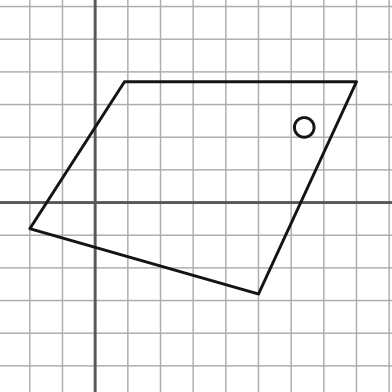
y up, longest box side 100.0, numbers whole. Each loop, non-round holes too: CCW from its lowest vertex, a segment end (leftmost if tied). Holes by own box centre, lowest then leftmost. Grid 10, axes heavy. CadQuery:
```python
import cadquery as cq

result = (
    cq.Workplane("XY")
    .moveTo(50.0, -28.0)
    .lineTo(80.0, 37.0)
    .lineTo(9.0, 37.0)
    .lineTo(-20.0, -8.0)
    .close()
    .moveTo(64.0, 23.0)
    .circle(3.0)
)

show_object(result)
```